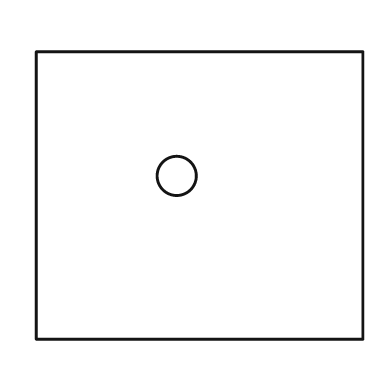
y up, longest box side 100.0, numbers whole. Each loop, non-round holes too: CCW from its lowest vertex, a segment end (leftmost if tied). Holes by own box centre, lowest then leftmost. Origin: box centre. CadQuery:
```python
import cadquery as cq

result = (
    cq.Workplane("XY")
    .moveTo(-50.0, -44.0)
    .lineTo(50.0, -44.0)
    .lineTo(50.0, 44.0)
    .lineTo(-50.0, 44.0)
    .close()
    .moveTo(-7.0, 6.0)
    .circle(6.0)
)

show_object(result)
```